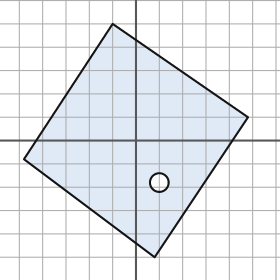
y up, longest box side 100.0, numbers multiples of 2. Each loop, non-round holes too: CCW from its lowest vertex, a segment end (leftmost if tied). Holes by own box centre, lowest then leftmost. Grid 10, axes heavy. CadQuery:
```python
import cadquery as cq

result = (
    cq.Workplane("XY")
    .moveTo(8.0, -50.0)
    .lineTo(48.0, 10.0)
    .lineTo(-10.0, 50.0)
    .lineTo(-48.0, -8.0)
    .close()
    .moveTo(10.0, -18.0)
    .circle(4.0)
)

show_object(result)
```